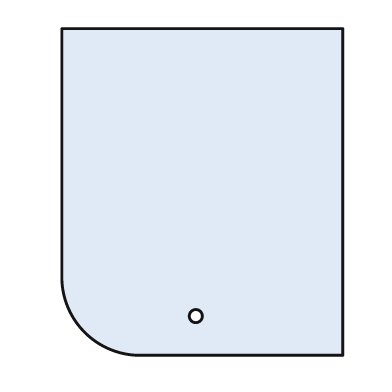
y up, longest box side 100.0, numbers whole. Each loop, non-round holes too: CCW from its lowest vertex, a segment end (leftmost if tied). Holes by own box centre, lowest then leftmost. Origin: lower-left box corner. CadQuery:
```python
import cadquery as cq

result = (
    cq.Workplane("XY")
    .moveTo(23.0, 0.0)
    .lineTo(86.0, 0.0)
    .lineTo(86.0, 100.0)
    .lineTo(0.0, 100.0)
    .lineTo(0.0, 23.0)
    .threePointArc((7.0, 7.0), (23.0, 0.0))
    .close()
    .moveTo(41.0, 12.0)
    .circle(2.0)
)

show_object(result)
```